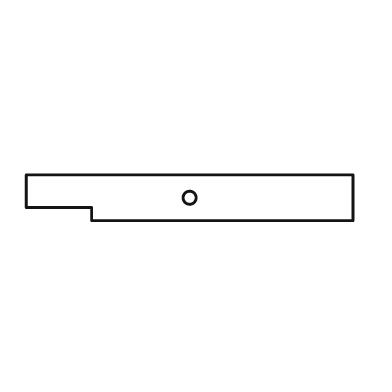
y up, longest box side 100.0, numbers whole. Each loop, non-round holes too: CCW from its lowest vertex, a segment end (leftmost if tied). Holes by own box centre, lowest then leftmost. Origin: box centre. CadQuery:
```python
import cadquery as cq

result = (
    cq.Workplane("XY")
    .moveTo(-30.0, -7.0)
    .lineTo(50.0, -7.0)
    .lineTo(50.0, 7.0)
    .lineTo(-50.0, 7.0)
    .lineTo(-50.0, -3.0)
    .lineTo(-30.0, -3.0)
    .close()
    .moveTo(0.0, 0.0)
    .circle(2.0)
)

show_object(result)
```